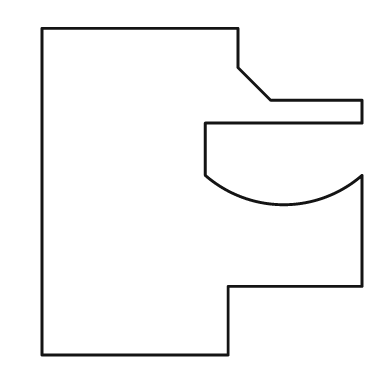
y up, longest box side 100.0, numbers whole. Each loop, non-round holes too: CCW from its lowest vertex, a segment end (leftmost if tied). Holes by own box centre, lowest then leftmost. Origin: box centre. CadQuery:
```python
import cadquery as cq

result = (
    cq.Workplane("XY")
    .moveTo(-49.0, -50.0)
    .lineTo(8.0, -50.0)
    .lineTo(8.0, -29.0)
    .lineTo(49.0, -29.0)
    .lineTo(49.0, 5.0)
    .threePointArc((25.0, -4.0), (1.0, 5.0))
    .lineTo(1.0, 21.0)
    .lineTo(49.0, 21.0)
    .lineTo(49.0, 28.0)
    .lineTo(21.0, 28.0)
    .lineTo(11.0, 38.0)
    .lineTo(11.0, 50.0)
    .lineTo(-49.0, 50.0)
    .close()
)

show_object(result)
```